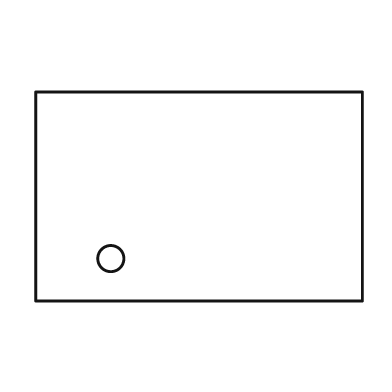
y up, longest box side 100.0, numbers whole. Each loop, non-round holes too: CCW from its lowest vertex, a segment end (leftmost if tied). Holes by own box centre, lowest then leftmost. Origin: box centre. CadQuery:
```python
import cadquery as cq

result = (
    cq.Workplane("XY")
    .moveTo(-50.0, -32.0)
    .lineTo(50.0, -32.0)
    .lineTo(50.0, 32.0)
    .lineTo(-50.0, 32.0)
    .close()
    .moveTo(-27.0, -19.0)
    .circle(4.0)
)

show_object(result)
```